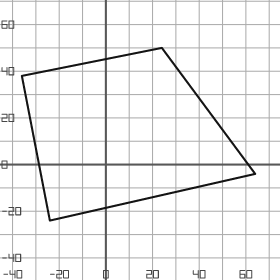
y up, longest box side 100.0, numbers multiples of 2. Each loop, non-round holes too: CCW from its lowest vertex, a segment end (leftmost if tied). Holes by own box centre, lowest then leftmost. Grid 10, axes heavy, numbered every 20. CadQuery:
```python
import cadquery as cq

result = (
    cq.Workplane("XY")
    .moveTo(-24.0, -24.0)
    .lineTo(64.0, -4.0)
    .lineTo(24.0, 50.0)
    .lineTo(-36.0, 38.0)
    .close()
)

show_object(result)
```